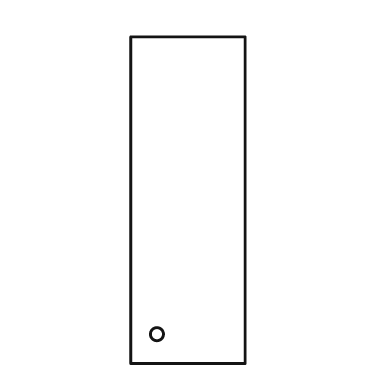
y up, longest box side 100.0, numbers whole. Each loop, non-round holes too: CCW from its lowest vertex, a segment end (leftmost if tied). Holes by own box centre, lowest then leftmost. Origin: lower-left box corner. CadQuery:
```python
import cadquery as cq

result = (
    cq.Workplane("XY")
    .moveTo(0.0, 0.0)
    .lineTo(35.0, 0.0)
    .lineTo(35.0, 100.0)
    .lineTo(0.0, 100.0)
    .close()
    .moveTo(8.0, 9.0)
    .circle(2.0)
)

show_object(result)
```